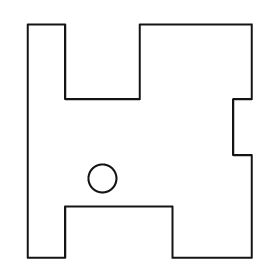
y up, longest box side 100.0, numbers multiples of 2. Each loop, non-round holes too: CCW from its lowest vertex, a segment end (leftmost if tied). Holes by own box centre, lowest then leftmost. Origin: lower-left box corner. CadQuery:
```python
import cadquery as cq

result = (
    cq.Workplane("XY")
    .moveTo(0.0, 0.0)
    .lineTo(16.0, 0.0)
    .lineTo(16.0, 22.0)
    .lineTo(62.0, 22.0)
    .lineTo(62.0, 0.0)
    .lineTo(96.0, 0.0)
    .lineTo(96.0, 44.0)
    .lineTo(88.0, 44.0)
    .lineTo(88.0, 68.0)
    .lineTo(96.0, 68.0)
    .lineTo(96.0, 100.0)
    .lineTo(48.0, 100.0)
    .lineTo(48.0, 68.0)
    .lineTo(16.0, 68.0)
    .lineTo(16.0, 100.0)
    .lineTo(0.0, 100.0)
    .close()
    .moveTo(32.0, 34.0)
    .circle(6.0)
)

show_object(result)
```